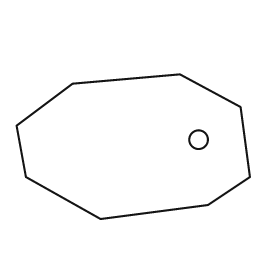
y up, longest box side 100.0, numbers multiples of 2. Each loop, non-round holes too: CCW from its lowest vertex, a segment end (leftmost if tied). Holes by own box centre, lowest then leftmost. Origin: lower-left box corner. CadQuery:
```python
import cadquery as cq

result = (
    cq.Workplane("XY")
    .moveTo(36.0, 0.0)
    .lineTo(82.0, 6.0)
    .lineTo(100.0, 18.0)
    .lineTo(96.0, 48.0)
    .lineTo(70.0, 62.0)
    .lineTo(24.0, 58.0)
    .lineTo(0.0, 40.0)
    .lineTo(4.0, 18.0)
    .close()
    .moveTo(78.0, 34.0)
    .circle(4.0)
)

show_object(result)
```